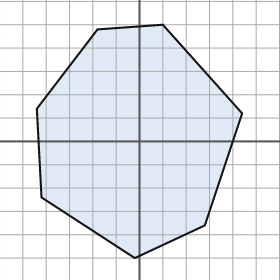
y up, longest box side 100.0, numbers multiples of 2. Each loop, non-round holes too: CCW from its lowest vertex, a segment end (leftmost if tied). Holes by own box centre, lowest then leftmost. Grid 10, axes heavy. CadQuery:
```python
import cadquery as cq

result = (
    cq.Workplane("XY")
    .moveTo(-2.0, -50.0)
    .lineTo(28.0, -36.0)
    .lineTo(44.0, 12.0)
    .lineTo(10.0, 50.0)
    .lineTo(-18.0, 48.0)
    .lineTo(-44.0, 14.0)
    .lineTo(-42.0, -24.0)
    .close()
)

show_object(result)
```